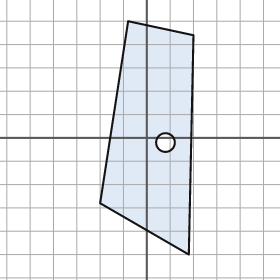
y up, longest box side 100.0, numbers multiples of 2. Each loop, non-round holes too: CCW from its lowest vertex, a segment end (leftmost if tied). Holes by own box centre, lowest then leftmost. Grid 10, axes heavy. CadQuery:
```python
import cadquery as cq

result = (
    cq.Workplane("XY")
    .moveTo(18.0, -50.0)
    .lineTo(20.0, 44.0)
    .lineTo(-8.0, 50.0)
    .lineTo(-20.0, -28.0)
    .close()
    .moveTo(8.0, -2.0)
    .circle(4.0)
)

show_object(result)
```